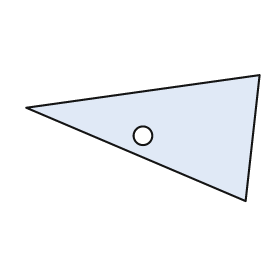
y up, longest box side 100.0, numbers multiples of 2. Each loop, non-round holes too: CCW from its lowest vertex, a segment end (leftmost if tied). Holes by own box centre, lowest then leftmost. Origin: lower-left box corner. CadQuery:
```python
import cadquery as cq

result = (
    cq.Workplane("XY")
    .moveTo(94.0, 0.0)
    .lineTo(100.0, 54.0)
    .lineTo(0.0, 40.0)
    .close()
    .moveTo(50.0, 28.0)
    .circle(4.0)
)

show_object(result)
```